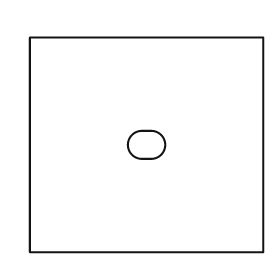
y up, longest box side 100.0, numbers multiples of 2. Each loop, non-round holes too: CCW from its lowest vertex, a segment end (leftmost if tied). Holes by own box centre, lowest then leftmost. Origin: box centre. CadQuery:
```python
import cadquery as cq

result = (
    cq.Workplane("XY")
    .moveTo(-50.0, -46.0)
    .lineTo(50.0, -46.0)
    .lineTo(50.0, 46.0)
    .lineTo(-50.0, 46.0)
    .close()
    .moveTo(-2.0, -6.0)
    .lineTo(2.0, -6.0)
    .threePointArc((8.0, 0.0), (2.0, 6.0))
    .lineTo(-2.0, 6.0)
    .threePointArc((-8.0, 0.0), (-2.0, -6.0))
    .close()
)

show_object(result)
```